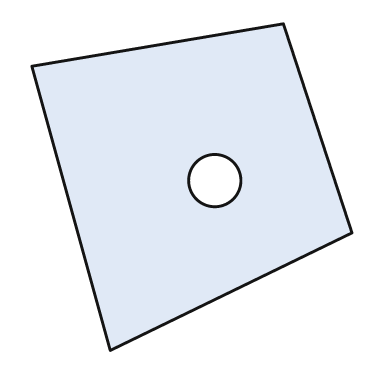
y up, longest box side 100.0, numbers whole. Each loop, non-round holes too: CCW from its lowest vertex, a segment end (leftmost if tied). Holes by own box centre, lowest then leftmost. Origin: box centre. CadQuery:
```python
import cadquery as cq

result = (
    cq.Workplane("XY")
    .moveTo(-25.0, -50.0)
    .lineTo(49.0, -14.0)
    .lineTo(28.0, 50.0)
    .lineTo(-49.0, 37.0)
    .close()
    .moveTo(7.0, 2.0)
    .circle(8.0)
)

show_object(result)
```